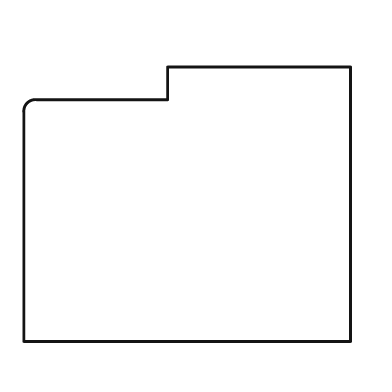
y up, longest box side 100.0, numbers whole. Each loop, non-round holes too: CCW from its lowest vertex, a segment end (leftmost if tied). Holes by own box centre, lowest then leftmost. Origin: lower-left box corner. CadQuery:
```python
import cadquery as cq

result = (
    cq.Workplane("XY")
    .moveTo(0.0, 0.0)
    .lineTo(100.0, 0.0)
    .lineTo(100.0, 84.0)
    .lineTo(44.0, 84.0)
    .lineTo(44.0, 74.0)
    .lineTo(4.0, 74.0)
    .threePointArc((1.0, 73.0), (0.0, 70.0))
    .close()
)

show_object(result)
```